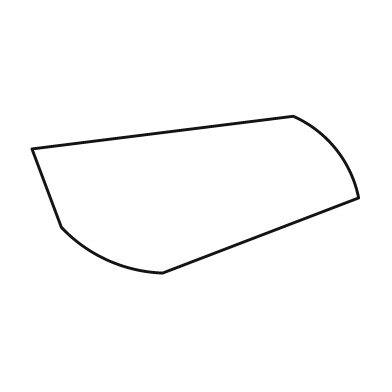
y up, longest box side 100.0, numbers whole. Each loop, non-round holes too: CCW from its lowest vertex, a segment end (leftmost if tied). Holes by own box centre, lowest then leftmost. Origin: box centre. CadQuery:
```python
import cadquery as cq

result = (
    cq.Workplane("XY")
    .moveTo(-10.0, -24.0)
    .lineTo(50.0, -1.0)
    .threePointArc((43.0, 14.0), (30.0, 24.0))
    .lineTo(-50.0, 14.0)
    .lineTo(-41.0, -10.0)
    .threePointArc((-27.0, -20.0), (-10.0, -24.0))
    .close()
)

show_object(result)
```